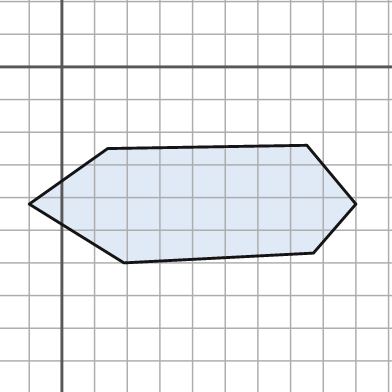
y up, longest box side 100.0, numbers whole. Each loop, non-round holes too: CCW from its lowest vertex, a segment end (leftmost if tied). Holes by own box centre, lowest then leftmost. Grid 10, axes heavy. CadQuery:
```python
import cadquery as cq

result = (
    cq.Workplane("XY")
    .moveTo(19.0, -60.0)
    .lineTo(77.0, -57.0)
    .lineTo(90.0, -42.0)
    .lineTo(75.0, -24.0)
    .lineTo(14.0, -25.0)
    .lineTo(-10.0, -42.0)
    .close()
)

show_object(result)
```